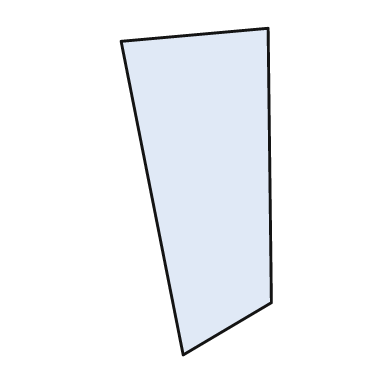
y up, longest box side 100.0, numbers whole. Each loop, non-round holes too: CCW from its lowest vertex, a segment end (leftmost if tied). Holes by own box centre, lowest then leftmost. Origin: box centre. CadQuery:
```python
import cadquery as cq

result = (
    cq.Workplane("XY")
    .moveTo(-4.0, -50.0)
    .lineTo(23.0, -34.0)
    .lineTo(22.0, 50.0)
    .lineTo(-23.0, 46.0)
    .close()
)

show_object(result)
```